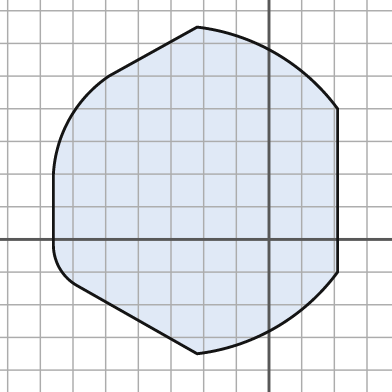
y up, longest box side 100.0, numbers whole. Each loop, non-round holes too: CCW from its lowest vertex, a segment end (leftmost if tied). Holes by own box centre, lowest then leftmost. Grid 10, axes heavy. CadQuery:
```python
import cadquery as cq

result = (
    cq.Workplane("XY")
    .moveTo(-22.0, -35.0)
    .threePointArc((2.0, -27.0), (21.0, -10.0))
    .lineTo(21.0, 40.0)
    .threePointArc((2.0, 57.0), (-22.0, 65.0))
    .lineTo(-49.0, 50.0)
    .threePointArc((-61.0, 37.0), (-66.0, 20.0))
    .lineTo(-66.0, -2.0)
    .threePointArc((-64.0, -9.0), (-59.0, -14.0))
    .close()
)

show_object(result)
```